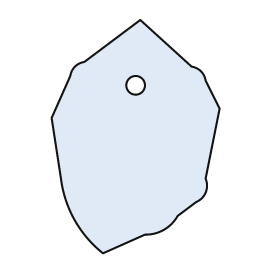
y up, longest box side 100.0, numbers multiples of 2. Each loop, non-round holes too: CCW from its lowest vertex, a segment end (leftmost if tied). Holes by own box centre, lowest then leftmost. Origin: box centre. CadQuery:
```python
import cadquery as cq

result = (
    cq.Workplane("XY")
    .moveTo(-14.0, -50.0)
    .lineTo(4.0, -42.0)
    .threePointArc((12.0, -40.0), (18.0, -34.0))
    .lineTo(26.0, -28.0)
    .threePointArc((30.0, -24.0), (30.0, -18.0))
    .lineTo(36.0, 12.0)
    .lineTo(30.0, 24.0)
    .threePointArc((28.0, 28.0), (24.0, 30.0))
    .lineTo(2.0, 50.0)
    .lineTo(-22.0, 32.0)
    .threePointArc((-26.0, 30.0), (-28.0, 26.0))
    .lineTo(-36.0, 8.0)
    .lineTo(-32.0, -18.0)
    .threePointArc((-26.0, -36.0), (-14.0, -50.0))
    .close()
    .moveTo(0.0, 22.0)
    .circle(4.0)
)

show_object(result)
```